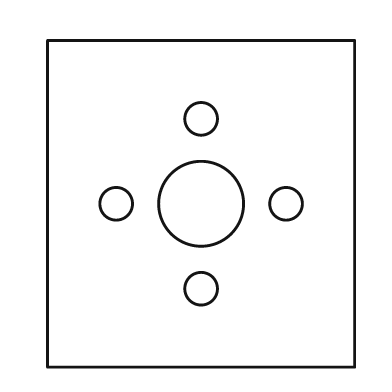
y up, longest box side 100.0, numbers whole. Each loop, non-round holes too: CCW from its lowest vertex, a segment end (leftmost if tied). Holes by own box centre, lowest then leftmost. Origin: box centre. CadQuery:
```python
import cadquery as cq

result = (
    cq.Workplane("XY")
    .moveTo(-47.0, -50.0)
    .lineTo(47.0, -50.0)
    .lineTo(47.0, 50.0)
    .lineTo(-47.0, 50.0)
    .close()
    .moveTo(0.0, -26.0)
    .circle(5.0)
    .moveTo(-26.0, 0.0)
    .circle(5.0)
    .moveTo(0.0, 0.0)
    .circle(13.0)
    .moveTo(26.0, 0.0)
    .circle(5.0)
    .moveTo(0.0, 26.0)
    .circle(5.0)
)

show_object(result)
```